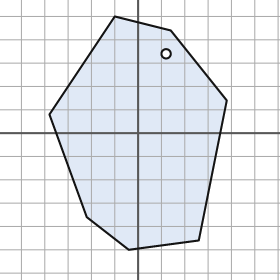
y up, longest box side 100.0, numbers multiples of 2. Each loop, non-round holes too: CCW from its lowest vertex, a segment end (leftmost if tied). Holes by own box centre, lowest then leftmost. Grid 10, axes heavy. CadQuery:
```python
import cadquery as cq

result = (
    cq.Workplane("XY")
    .moveTo(-4.0, -50.0)
    .lineTo(26.0, -46.0)
    .lineTo(38.0, 14.0)
    .lineTo(14.0, 44.0)
    .lineTo(-10.0, 50.0)
    .lineTo(-38.0, 8.0)
    .lineTo(-22.0, -36.0)
    .close()
    .moveTo(12.0, 34.0)
    .circle(2.0)
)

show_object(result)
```